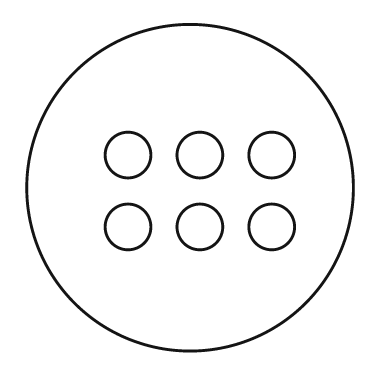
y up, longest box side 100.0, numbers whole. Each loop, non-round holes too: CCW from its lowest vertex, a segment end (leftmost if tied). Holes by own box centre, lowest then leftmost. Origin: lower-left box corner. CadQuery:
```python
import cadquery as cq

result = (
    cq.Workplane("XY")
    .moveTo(50.0, 50.0)
    .circle(50.0)
    .moveTo(31.0, 38.0)
    .circle(7.0)
    .moveTo(53.0, 38.0)
    .circle(7.0)
    .moveTo(75.0, 38.0)
    .circle(7.0)
    .moveTo(31.0, 60.0)
    .circle(7.0)
    .moveTo(53.0, 60.0)
    .circle(7.0)
    .moveTo(75.0, 60.0)
    .circle(7.0)
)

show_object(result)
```